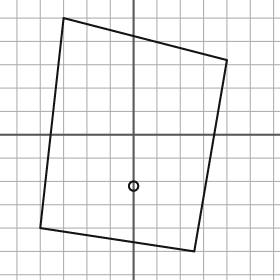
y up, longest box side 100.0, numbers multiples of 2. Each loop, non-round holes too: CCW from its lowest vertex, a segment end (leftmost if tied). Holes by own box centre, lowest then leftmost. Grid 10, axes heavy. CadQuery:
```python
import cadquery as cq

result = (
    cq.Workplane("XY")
    .moveTo(26.0, -50.0)
    .lineTo(40.0, 32.0)
    .lineTo(-30.0, 50.0)
    .lineTo(-40.0, -40.0)
    .close()
    .moveTo(0.0, -22.0)
    .circle(2.0)
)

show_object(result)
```